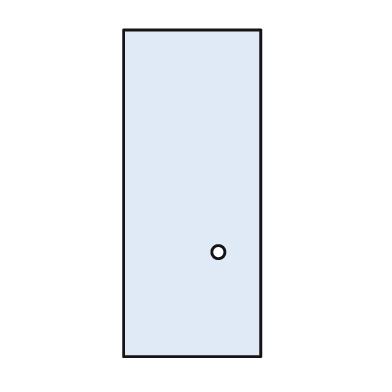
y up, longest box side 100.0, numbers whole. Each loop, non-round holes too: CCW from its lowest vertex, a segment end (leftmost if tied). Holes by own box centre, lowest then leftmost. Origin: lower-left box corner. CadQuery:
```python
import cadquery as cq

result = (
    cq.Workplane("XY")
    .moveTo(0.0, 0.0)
    .lineTo(42.0, 0.0)
    .lineTo(42.0, 100.0)
    .lineTo(0.0, 100.0)
    .close()
    .moveTo(29.0, 32.0)
    .circle(2.0)
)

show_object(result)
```